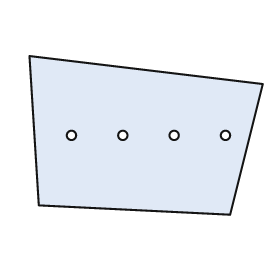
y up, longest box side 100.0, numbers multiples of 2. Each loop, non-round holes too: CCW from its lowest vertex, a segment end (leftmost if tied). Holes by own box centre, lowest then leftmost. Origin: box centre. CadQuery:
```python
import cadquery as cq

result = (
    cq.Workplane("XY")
    .moveTo(36.0, -34.0)
    .lineTo(50.0, 22.0)
    .lineTo(-50.0, 34.0)
    .lineTo(-46.0, -30.0)
    .close()
    .moveTo(-32.0, 0.0)
    .circle(2.0)
    .moveTo(-10.0, 0.0)
    .circle(2.0)
    .moveTo(12.0, 0.0)
    .circle(2.0)
    .moveTo(34.0, 0.0)
    .circle(2.0)
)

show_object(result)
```